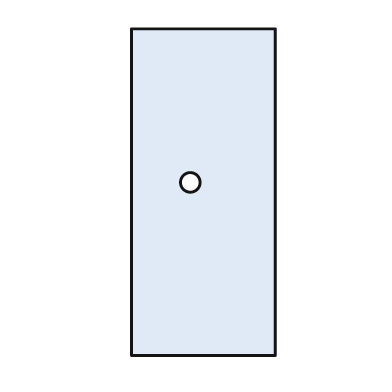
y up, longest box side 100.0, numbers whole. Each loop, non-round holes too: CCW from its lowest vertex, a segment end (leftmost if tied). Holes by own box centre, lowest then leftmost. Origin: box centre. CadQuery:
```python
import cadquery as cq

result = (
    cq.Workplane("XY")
    .moveTo(-22.0, -50.0)
    .lineTo(22.0, -50.0)
    .lineTo(22.0, 50.0)
    .lineTo(-22.0, 50.0)
    .close()
    .moveTo(-4.0, 3.0)
    .circle(3.0)
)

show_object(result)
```